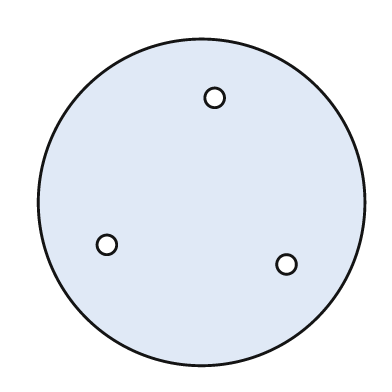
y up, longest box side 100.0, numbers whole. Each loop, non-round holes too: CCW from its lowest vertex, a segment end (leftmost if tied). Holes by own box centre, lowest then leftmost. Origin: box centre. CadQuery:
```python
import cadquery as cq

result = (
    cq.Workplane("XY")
    .moveTo(0.0, 0.0)
    .circle(50.0)
    .moveTo(26.0, -19.0)
    .circle(3.0)
    .moveTo(-29.0, -13.0)
    .circle(3.0)
    .moveTo(4.0, 32.0)
    .circle(3.0)
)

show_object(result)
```